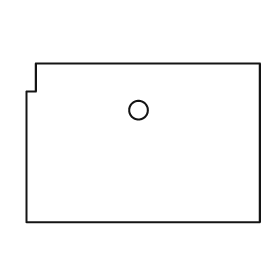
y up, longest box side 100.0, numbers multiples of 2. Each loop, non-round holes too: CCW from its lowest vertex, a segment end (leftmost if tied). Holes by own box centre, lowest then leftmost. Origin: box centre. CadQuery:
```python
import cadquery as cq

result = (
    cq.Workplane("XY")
    .moveTo(-50.0, -34.0)
    .lineTo(50.0, -34.0)
    .lineTo(50.0, 34.0)
    .lineTo(-46.0, 34.0)
    .lineTo(-46.0, 22.0)
    .lineTo(-50.0, 22.0)
    .close()
    .moveTo(-2.0, 14.0)
    .circle(4.0)
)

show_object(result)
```